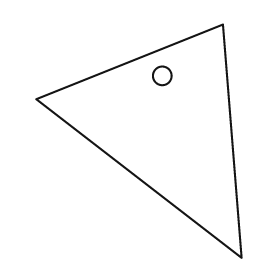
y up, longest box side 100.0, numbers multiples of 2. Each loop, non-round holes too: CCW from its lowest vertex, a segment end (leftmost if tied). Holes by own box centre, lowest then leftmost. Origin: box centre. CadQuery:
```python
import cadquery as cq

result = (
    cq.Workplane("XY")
    .moveTo(44.0, -50.0)
    .lineTo(36.0, 50.0)
    .lineTo(-44.0, 18.0)
    .close()
    .moveTo(10.0, 28.0)
    .circle(4.0)
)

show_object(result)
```